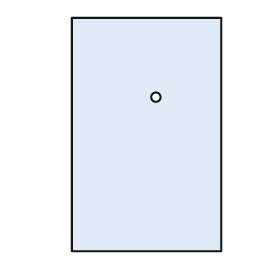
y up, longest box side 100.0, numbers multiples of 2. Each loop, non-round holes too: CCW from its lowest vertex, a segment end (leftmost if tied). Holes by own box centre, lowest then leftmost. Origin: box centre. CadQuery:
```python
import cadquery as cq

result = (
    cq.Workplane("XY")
    .moveTo(-32.0, -50.0)
    .lineTo(32.0, -50.0)
    .lineTo(32.0, 50.0)
    .lineTo(-32.0, 50.0)
    .close()
    .moveTo(4.0, 16.0)
    .circle(2.0)
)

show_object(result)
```